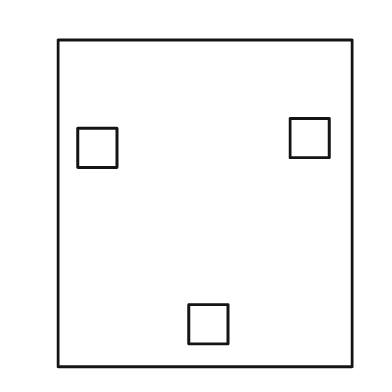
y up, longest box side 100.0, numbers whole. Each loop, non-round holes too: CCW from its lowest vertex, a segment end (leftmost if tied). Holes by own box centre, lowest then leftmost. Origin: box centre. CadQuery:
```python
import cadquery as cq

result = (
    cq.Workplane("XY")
    .moveTo(-45.0, -50.0)
    .lineTo(45.0, -50.0)
    .lineTo(45.0, 50.0)
    .lineTo(-45.0, 50.0)
    .close()
    .moveTo(-5.0, -43.0)
    .lineTo(7.0, -43.0)
    .lineTo(7.0, -31.0)
    .lineTo(-5.0, -31.0)
    .close()
    .moveTo(-39.0, 11.0)
    .lineTo(-27.0, 11.0)
    .lineTo(-27.0, 23.0)
    .lineTo(-39.0, 23.0)
    .close()
    .moveTo(26.0, 14.0)
    .lineTo(38.0, 14.0)
    .lineTo(38.0, 26.0)
    .lineTo(26.0, 26.0)
    .close()
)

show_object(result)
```